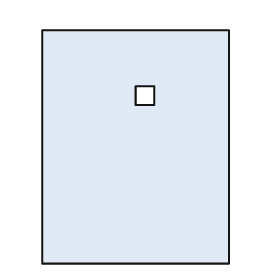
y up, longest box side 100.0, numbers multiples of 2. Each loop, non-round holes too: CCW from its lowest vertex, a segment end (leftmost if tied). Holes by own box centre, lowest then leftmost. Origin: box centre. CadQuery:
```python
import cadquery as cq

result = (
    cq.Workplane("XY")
    .moveTo(-40.0, -50.0)
    .lineTo(40.0, -50.0)
    .lineTo(40.0, 50.0)
    .lineTo(-40.0, 50.0)
    .close()
    .moveTo(0.0, 18.0)
    .lineTo(8.0, 18.0)
    .lineTo(8.0, 26.0)
    .lineTo(0.0, 26.0)
    .close()
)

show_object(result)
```